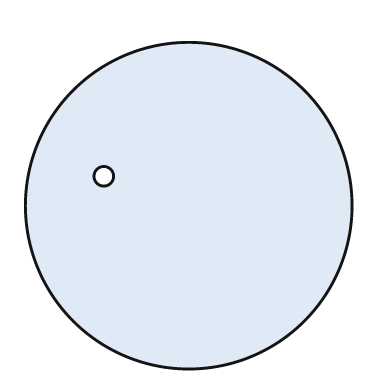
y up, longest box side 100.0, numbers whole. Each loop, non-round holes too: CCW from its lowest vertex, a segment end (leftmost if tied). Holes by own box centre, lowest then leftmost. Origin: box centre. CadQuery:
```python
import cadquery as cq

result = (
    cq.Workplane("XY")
    .moveTo(0.0, 0.0)
    .circle(50.0)
    .moveTo(-26.0, 9.0)
    .circle(3.0)
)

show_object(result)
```